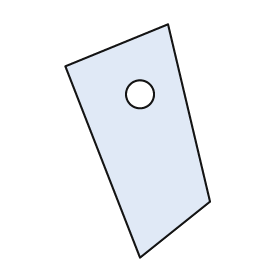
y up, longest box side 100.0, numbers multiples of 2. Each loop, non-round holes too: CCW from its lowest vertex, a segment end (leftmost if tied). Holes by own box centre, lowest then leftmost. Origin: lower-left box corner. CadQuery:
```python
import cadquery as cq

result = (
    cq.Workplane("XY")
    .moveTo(32.0, 0.0)
    .lineTo(62.0, 24.0)
    .lineTo(44.0, 100.0)
    .lineTo(0.0, 82.0)
    .close()
    .moveTo(32.0, 70.0)
    .circle(6.0)
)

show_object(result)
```